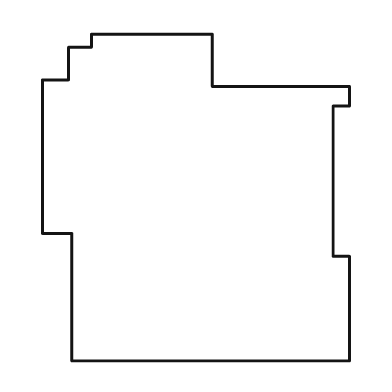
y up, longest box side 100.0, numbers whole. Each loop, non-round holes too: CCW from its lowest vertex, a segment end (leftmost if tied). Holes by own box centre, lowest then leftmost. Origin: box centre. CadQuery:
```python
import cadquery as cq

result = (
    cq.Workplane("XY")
    .moveTo(-38.0, -50.0)
    .lineTo(47.0, -50.0)
    .lineTo(47.0, -18.0)
    .lineTo(42.0, -18.0)
    .lineTo(42.0, 28.0)
    .lineTo(47.0, 28.0)
    .lineTo(47.0, 34.0)
    .lineTo(5.0, 34.0)
    .lineTo(5.0, 50.0)
    .lineTo(-32.0, 50.0)
    .lineTo(-32.0, 46.0)
    .lineTo(-39.0, 46.0)
    .lineTo(-39.0, 36.0)
    .lineTo(-47.0, 36.0)
    .lineTo(-47.0, -11.0)
    .lineTo(-38.0, -11.0)
    .close()
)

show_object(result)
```